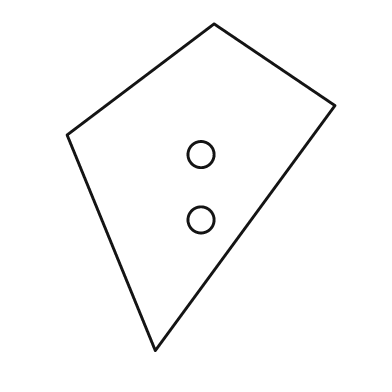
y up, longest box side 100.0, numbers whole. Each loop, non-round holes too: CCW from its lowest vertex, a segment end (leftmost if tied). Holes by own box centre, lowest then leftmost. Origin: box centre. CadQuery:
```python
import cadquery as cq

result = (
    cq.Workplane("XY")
    .moveTo(-14.0, -50.0)
    .lineTo(41.0, 25.0)
    .lineTo(4.0, 50.0)
    .lineTo(-41.0, 16.0)
    .close()
    .moveTo(0.0, -10.0)
    .circle(4.0)
    .moveTo(0.0, 10.0)
    .circle(4.0)
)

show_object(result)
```